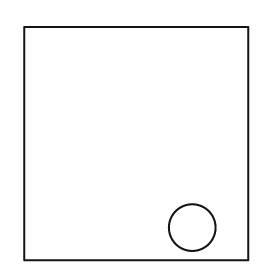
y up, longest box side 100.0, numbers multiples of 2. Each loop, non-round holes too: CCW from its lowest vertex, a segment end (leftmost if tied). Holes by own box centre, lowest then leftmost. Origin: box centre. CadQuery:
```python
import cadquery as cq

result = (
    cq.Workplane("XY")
    .moveTo(-48.0, -50.0)
    .lineTo(48.0, -50.0)
    .lineTo(48.0, 50.0)
    .lineTo(-48.0, 50.0)
    .close()
    .moveTo(24.0, -36.0)
    .circle(10.0)
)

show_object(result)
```